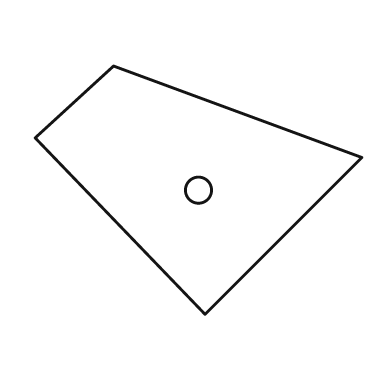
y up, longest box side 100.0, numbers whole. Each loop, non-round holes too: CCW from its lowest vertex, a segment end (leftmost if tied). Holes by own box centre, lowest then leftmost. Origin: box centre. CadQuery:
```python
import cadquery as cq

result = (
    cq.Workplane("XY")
    .moveTo(2.0, -38.0)
    .lineTo(50.0, 10.0)
    .lineTo(-26.0, 38.0)
    .lineTo(-50.0, 16.0)
    .close()
    .moveTo(0.0, 0.0)
    .circle(4.0)
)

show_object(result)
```